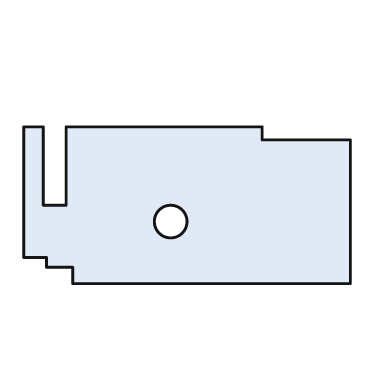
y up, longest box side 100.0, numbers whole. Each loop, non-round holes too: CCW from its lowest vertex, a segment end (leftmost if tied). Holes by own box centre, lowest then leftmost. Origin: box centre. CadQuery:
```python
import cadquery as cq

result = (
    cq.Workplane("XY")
    .moveTo(-35.0, -24.0)
    .lineTo(50.0, -24.0)
    .lineTo(50.0, 20.0)
    .lineTo(23.0, 20.0)
    .lineTo(23.0, 24.0)
    .lineTo(-37.0, 24.0)
    .lineTo(-37.0, 0.0)
    .lineTo(-44.0, 0.0)
    .lineTo(-44.0, 24.0)
    .lineTo(-50.0, 24.0)
    .lineTo(-50.0, -16.0)
    .lineTo(-43.0, -16.0)
    .lineTo(-43.0, -19.0)
    .lineTo(-35.0, -19.0)
    .close()
    .moveTo(-5.0, -5.0)
    .circle(5.0)
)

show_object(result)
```